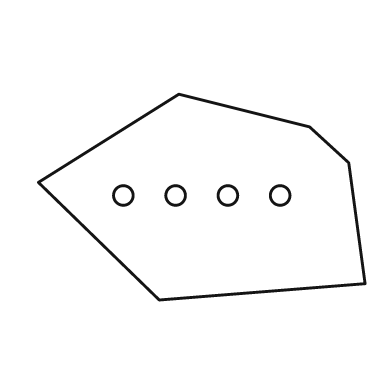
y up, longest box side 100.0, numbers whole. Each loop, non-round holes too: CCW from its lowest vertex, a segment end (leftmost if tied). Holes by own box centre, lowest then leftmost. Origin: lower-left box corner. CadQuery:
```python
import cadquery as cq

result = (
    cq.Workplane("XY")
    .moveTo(37.0, 0.0)
    .lineTo(100.0, 5.0)
    .lineTo(95.0, 42.0)
    .lineTo(83.0, 53.0)
    .lineTo(43.0, 63.0)
    .lineTo(0.0, 36.0)
    .close()
    .moveTo(26.0, 32.0)
    .circle(3.0)
    .moveTo(42.0, 32.0)
    .circle(3.0)
    .moveTo(58.0, 32.0)
    .circle(3.0)
    .moveTo(74.0, 32.0)
    .circle(3.0)
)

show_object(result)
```